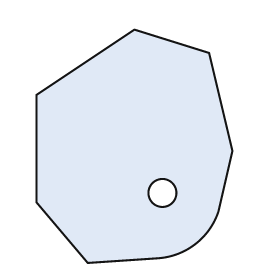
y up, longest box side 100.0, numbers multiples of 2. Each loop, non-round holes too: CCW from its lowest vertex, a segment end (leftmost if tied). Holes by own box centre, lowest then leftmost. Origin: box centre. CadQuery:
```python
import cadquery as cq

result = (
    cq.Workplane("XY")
    .moveTo(-20.0, -50.0)
    .lineTo(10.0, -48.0)
    .threePointArc((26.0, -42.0), (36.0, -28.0))
    .lineTo(42.0, -2.0)
    .lineTo(32.0, 40.0)
    .lineTo(0.0, 50.0)
    .lineTo(-42.0, 22.0)
    .lineTo(-42.0, -24.0)
    .close()
    .moveTo(12.0, -20.0)
    .circle(6.0)
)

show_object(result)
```